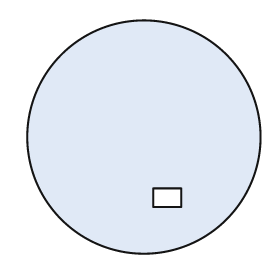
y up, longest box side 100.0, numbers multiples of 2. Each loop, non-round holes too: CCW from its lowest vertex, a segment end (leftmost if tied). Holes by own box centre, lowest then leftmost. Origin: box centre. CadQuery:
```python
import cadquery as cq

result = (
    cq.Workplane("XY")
    .moveTo(0.0, 0.0)
    .circle(50.0)
    .moveTo(4.0, -30.0)
    .lineTo(16.0, -30.0)
    .lineTo(16.0, -22.0)
    .lineTo(4.0, -22.0)
    .close()
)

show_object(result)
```